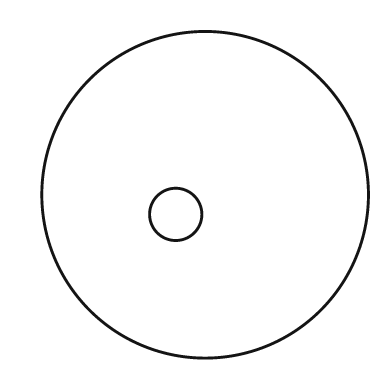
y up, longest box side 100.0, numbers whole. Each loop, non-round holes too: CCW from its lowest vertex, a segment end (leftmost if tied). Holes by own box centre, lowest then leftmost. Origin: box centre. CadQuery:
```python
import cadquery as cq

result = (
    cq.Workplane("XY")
    .moveTo(0.0, 0.0)
    .circle(50.0)
    .moveTo(-9.0, -6.0)
    .circle(8.0)
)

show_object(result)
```